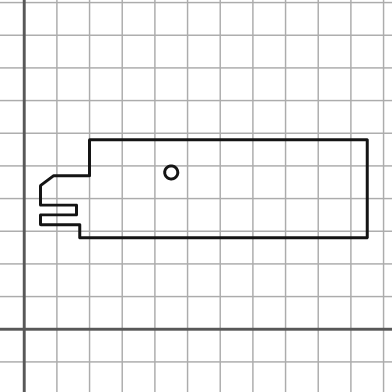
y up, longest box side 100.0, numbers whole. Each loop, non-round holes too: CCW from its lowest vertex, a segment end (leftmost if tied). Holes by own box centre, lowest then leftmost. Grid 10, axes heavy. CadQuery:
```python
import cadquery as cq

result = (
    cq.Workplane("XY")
    .moveTo(17.0, 28.0)
    .lineTo(105.0, 28.0)
    .lineTo(105.0, 58.0)
    .lineTo(20.0, 58.0)
    .lineTo(20.0, 47.0)
    .lineTo(9.0, 47.0)
    .lineTo(5.0, 44.0)
    .lineTo(5.0, 38.0)
    .lineTo(16.0, 38.0)
    .lineTo(16.0, 35.0)
    .lineTo(5.0, 35.0)
    .lineTo(5.0, 32.0)
    .lineTo(17.0, 32.0)
    .close()
    .moveTo(45.0, 48.0)
    .circle(2.0)
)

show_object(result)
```